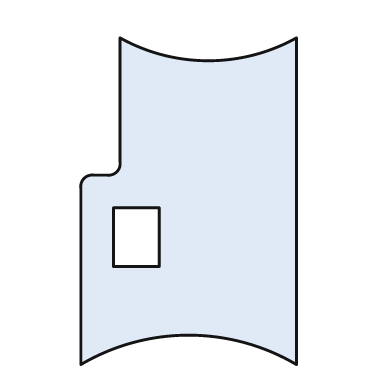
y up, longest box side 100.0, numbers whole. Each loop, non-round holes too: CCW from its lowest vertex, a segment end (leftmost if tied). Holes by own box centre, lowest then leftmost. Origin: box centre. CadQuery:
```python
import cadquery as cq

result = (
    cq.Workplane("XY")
    .moveTo(-33.0, -50.0)
    .threePointArc((0.0, -41.0), (33.0, -50.0))
    .lineTo(33.0, 50.0)
    .threePointArc((6.0, 43.0), (-21.0, 50.0))
    .lineTo(-21.0, 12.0)
    .threePointArc((-22.0, 9.0), (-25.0, 8.0))
    .lineTo(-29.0, 8.0)
    .threePointArc((-32.0, 7.0), (-33.0, 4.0))
    .close()
    .moveTo(-23.0, -20.0)
    .lineTo(-9.0, -20.0)
    .lineTo(-9.0, -2.0)
    .lineTo(-23.0, -2.0)
    .close()
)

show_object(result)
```